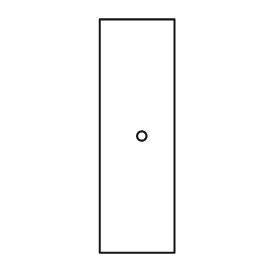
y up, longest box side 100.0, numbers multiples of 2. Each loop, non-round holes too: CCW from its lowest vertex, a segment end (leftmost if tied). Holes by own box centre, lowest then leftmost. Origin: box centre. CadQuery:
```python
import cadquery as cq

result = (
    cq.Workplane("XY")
    .moveTo(-16.0, -50.0)
    .lineTo(16.0, -50.0)
    .lineTo(16.0, 50.0)
    .lineTo(-16.0, 50.0)
    .close()
    .moveTo(2.0, 0.0)
    .circle(2.0)
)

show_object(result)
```